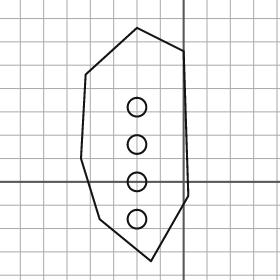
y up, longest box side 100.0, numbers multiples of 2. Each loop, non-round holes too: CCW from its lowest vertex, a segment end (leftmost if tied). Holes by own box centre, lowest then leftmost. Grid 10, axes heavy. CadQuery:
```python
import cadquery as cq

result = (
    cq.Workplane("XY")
    .moveTo(-14.0, -34.0)
    .lineTo(2.0, -6.0)
    .lineTo(0.0, 56.0)
    .lineTo(-20.0, 66.0)
    .lineTo(-42.0, 46.0)
    .lineTo(-44.0, 10.0)
    .lineTo(-36.0, -16.0)
    .close()
    .moveTo(-20.0, -16.0)
    .circle(4.0)
    .moveTo(-20.0, 0.0)
    .circle(4.0)
    .moveTo(-20.0, 16.0)
    .circle(4.0)
    .moveTo(-20.0, 32.0)
    .circle(4.0)
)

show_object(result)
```